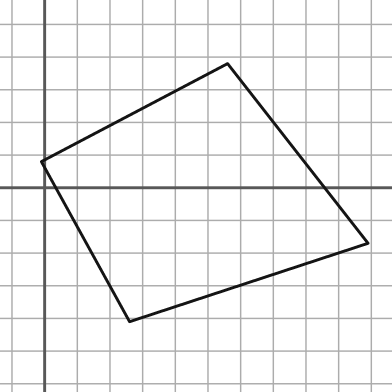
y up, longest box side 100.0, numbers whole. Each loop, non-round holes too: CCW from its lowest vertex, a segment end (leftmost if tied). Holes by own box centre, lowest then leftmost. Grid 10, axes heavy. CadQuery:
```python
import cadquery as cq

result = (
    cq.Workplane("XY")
    .moveTo(26.0, -41.0)
    .lineTo(99.0, -17.0)
    .lineTo(56.0, 38.0)
    .lineTo(-1.0, 8.0)
    .close()
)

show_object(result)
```